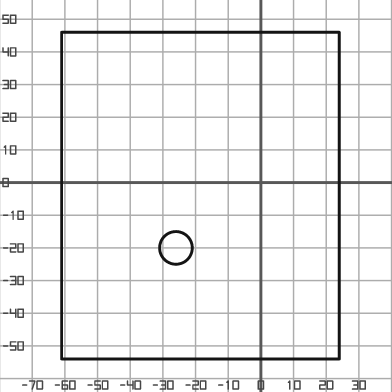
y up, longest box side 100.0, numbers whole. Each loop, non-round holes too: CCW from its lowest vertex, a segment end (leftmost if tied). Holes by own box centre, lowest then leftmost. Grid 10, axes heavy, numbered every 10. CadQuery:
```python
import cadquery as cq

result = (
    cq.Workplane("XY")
    .moveTo(-61.0, -54.0)
    .lineTo(24.0, -54.0)
    .lineTo(24.0, 46.0)
    .lineTo(-61.0, 46.0)
    .close()
    .moveTo(-26.0, -20.0)
    .circle(5.0)
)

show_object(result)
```